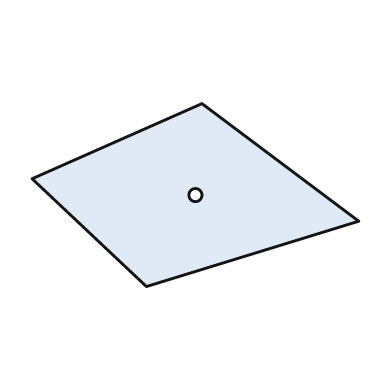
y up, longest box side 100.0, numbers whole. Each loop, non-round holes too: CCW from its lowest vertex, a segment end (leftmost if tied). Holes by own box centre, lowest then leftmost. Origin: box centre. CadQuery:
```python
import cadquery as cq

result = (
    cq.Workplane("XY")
    .moveTo(-15.0, -28.0)
    .lineTo(50.0, -8.0)
    .lineTo(2.0, 28.0)
    .lineTo(-50.0, 5.0)
    .close()
    .moveTo(0.0, 0.0)
    .circle(2.0)
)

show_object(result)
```